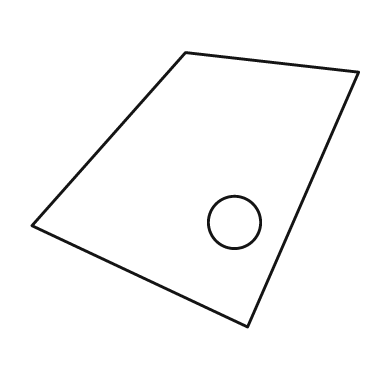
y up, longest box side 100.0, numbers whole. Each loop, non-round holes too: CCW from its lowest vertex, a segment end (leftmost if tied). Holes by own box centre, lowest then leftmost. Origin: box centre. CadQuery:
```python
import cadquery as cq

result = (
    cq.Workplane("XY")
    .moveTo(16.0, -42.0)
    .lineTo(50.0, 36.0)
    .lineTo(-3.0, 42.0)
    .lineTo(-50.0, -11.0)
    .close()
    .moveTo(12.0, -10.0)
    .circle(8.0)
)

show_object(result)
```